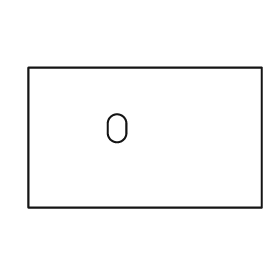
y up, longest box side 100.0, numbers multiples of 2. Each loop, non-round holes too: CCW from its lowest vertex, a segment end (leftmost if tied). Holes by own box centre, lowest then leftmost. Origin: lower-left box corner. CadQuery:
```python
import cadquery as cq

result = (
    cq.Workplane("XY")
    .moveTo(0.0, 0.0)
    .lineTo(100.0, 0.0)
    .lineTo(100.0, 60.0)
    .lineTo(0.0, 60.0)
    .close()
    .moveTo(34.0, 32.0)
    .threePointArc((38.0, 28.0), (42.0, 32.0))
    .lineTo(42.0, 36.0)
    .threePointArc((38.0, 40.0), (34.0, 36.0))
    .close()
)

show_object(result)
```